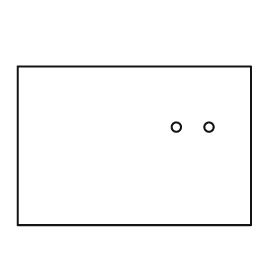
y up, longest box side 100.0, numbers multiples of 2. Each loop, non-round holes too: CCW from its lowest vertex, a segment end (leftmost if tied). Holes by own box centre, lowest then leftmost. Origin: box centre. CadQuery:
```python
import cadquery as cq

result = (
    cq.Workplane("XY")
    .moveTo(-50.0, -34.0)
    .lineTo(50.0, -34.0)
    .lineTo(50.0, 34.0)
    .lineTo(-50.0, 34.0)
    .close()
    .moveTo(18.0, 8.0)
    .circle(2.0)
    .moveTo(32.0, 8.0)
    .circle(2.0)
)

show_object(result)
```